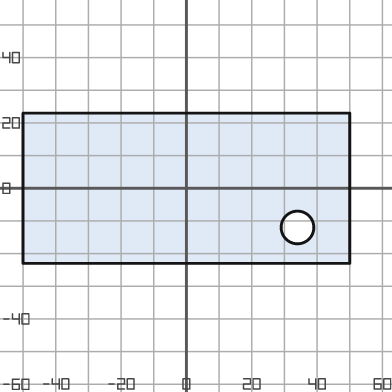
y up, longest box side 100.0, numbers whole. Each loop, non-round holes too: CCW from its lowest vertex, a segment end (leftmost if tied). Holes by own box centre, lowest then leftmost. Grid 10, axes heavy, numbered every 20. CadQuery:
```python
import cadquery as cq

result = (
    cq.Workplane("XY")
    .moveTo(-50.0, -23.0)
    .lineTo(50.0, -23.0)
    .lineTo(50.0, 23.0)
    .lineTo(-50.0, 23.0)
    .close()
    .moveTo(34.0, -12.0)
    .circle(5.0)
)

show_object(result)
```